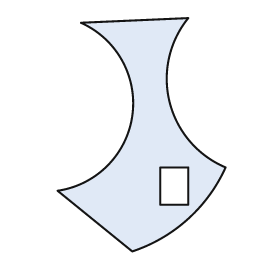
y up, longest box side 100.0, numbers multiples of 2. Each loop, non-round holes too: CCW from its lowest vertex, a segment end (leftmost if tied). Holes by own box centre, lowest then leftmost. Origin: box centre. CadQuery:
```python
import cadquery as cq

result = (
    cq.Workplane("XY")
    .moveTo(-4.0, -50.0)
    .threePointArc((20.0, -36.0), (36.0, -14.0))
    .threePointArc((12.0, 14.0), (20.0, 50.0))
    .lineTo(-26.0, 48.0)
    .threePointArc((-4.0, 8.0), (-36.0, -24.0))
    .close()
    .moveTo(8.0, -30.0)
    .lineTo(20.0, -30.0)
    .lineTo(20.0, -14.0)
    .lineTo(8.0, -14.0)
    .close()
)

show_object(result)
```